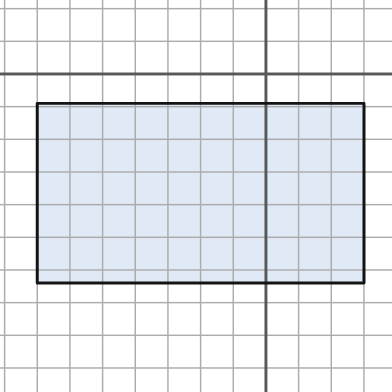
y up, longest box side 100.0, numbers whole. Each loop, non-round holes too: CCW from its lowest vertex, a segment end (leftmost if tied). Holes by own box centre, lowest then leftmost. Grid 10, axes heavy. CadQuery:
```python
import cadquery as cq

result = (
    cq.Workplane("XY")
    .moveTo(-70.0, -64.0)
    .lineTo(30.0, -64.0)
    .lineTo(30.0, -9.0)
    .lineTo(-70.0, -9.0)
    .close()
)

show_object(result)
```